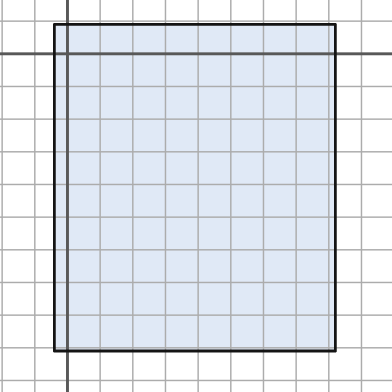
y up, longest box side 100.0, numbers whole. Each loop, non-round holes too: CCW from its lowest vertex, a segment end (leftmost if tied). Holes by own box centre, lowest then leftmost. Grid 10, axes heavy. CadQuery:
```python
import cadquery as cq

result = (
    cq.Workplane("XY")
    .moveTo(-4.0, -91.0)
    .lineTo(82.0, -91.0)
    .lineTo(82.0, 9.0)
    .lineTo(-4.0, 9.0)
    .close()
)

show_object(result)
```